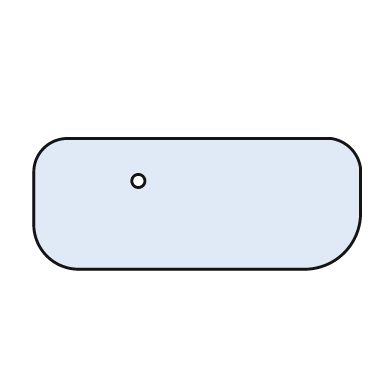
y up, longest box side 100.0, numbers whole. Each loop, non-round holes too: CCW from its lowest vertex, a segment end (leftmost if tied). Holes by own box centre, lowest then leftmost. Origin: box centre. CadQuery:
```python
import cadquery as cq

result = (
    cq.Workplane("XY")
    .moveTo(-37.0, -20.0)
    .lineTo(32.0, -20.0)
    .threePointArc((45.0, -15.0), (50.0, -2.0))
    .lineTo(50.0, 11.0)
    .threePointArc((47.0, 17.0), (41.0, 20.0))
    .lineTo(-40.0, 20.0)
    .threePointArc((-47.0, 17.0), (-50.0, 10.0))
    .lineTo(-50.0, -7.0)
    .threePointArc((-46.0, -16.0), (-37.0, -20.0))
    .close()
    .moveTo(-18.0, 7.0)
    .circle(2.0)
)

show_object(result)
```